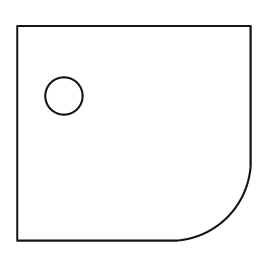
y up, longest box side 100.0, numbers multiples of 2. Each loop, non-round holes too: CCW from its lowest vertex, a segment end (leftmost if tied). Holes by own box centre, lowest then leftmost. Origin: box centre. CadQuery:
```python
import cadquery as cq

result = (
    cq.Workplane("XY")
    .moveTo(-50.0, -46.0)
    .lineTo(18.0, -46.0)
    .threePointArc((40.0, -36.0), (50.0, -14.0))
    .lineTo(50.0, 46.0)
    .lineTo(-50.0, 46.0)
    .close()
    .moveTo(-30.0, 16.0)
    .circle(8.0)
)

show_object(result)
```